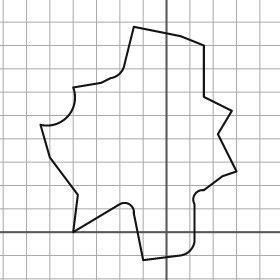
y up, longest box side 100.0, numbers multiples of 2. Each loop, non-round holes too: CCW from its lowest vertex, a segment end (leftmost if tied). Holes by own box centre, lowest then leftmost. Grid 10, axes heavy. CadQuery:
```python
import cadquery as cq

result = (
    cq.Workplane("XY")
    .moveTo(-10.0, -12.0)
    .lineTo(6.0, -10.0)
    .threePointArc((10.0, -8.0), (12.0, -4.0))
    .lineTo(12.0, 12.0)
    .threePointArc((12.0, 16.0), (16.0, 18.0))
    .lineTo(24.0, 24.0)
    .lineTo(30.0, 26.0)
    .lineTo(22.0, 42.0)
    .lineTo(28.0, 52.0)
    .lineTo(16.0, 58.0)
    .lineTo(16.0, 80.0)
    .lineTo(6.0, 84.0)
    .lineTo(-14.0, 88.0)
    .lineTo(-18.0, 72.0)
    .threePointArc((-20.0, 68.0), (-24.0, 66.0))
    .lineTo(-28.0, 64.0)
    .lineTo(-40.0, 62.0)
    .threePointArc((-42.0, 50.0), (-54.0, 46.0))
    .lineTo(-50.0, 32.0)
    .lineTo(-38.0, 16.0)
    .lineTo(-40.0, 0.0)
    .lineTo(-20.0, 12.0)
    .threePointArc((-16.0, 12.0), (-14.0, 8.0))
    .close()
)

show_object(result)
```